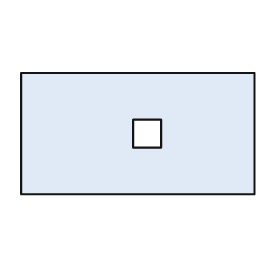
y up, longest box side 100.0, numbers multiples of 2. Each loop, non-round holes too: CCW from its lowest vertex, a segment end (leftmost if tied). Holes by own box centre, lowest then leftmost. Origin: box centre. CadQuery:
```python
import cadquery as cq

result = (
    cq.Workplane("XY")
    .moveTo(-50.0, -26.0)
    .lineTo(50.0, -26.0)
    .lineTo(50.0, 26.0)
    .lineTo(-50.0, 26.0)
    .close()
    .moveTo(-2.0, -6.0)
    .lineTo(10.0, -6.0)
    .lineTo(10.0, 6.0)
    .lineTo(-2.0, 6.0)
    .close()
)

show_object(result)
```